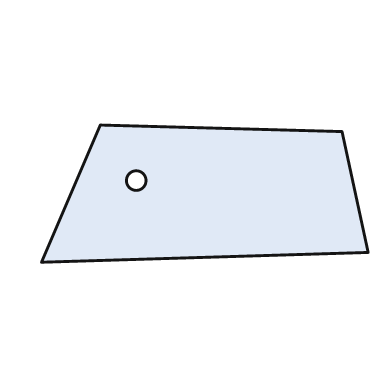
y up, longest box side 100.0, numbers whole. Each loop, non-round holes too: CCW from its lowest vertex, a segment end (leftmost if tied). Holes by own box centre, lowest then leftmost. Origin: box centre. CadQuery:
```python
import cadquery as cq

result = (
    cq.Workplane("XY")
    .moveTo(-50.0, -21.0)
    .lineTo(50.0, -18.0)
    .lineTo(42.0, 19.0)
    .lineTo(-32.0, 21.0)
    .close()
    .moveTo(-21.0, 4.0)
    .circle(3.0)
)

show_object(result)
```